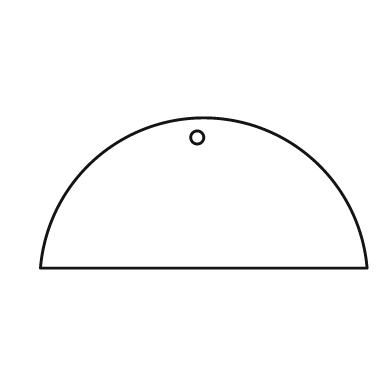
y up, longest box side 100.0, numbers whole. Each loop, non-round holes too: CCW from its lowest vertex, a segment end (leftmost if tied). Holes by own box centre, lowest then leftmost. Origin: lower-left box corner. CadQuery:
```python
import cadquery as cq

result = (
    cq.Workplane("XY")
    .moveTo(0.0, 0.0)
    .lineTo(100.0, 0.0)
    .threePointArc((50.0, 46.0), (0.0, 0.0))
    .close()
    .moveTo(48.0, 40.0)
    .circle(2.0)
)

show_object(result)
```